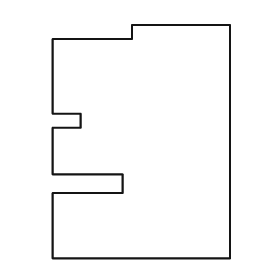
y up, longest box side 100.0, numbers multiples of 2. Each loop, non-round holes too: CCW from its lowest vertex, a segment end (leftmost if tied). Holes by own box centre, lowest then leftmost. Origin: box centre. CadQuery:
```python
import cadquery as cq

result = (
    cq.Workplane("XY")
    .moveTo(-38.0, -50.0)
    .lineTo(38.0, -50.0)
    .lineTo(38.0, 50.0)
    .lineTo(-4.0, 50.0)
    .lineTo(-4.0, 44.0)
    .lineTo(-38.0, 44.0)
    .lineTo(-38.0, 12.0)
    .lineTo(-26.0, 12.0)
    .lineTo(-26.0, 6.0)
    .lineTo(-38.0, 6.0)
    .lineTo(-38.0, -14.0)
    .lineTo(-8.0, -14.0)
    .lineTo(-8.0, -22.0)
    .lineTo(-38.0, -22.0)
    .close()
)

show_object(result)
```